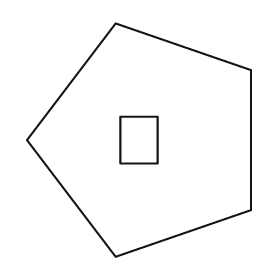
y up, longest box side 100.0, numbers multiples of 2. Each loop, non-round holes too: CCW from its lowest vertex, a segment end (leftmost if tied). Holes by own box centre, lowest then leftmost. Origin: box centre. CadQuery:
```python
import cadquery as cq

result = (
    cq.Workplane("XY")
    .moveTo(-10.0, -50.0)
    .lineTo(48.0, -30.0)
    .lineTo(48.0, 30.0)
    .lineTo(-10.0, 50.0)
    .lineTo(-48.0, 0.0)
    .close()
    .moveTo(-8.0, -10.0)
    .lineTo(8.0, -10.0)
    .lineTo(8.0, 10.0)
    .lineTo(-8.0, 10.0)
    .close()
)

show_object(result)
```